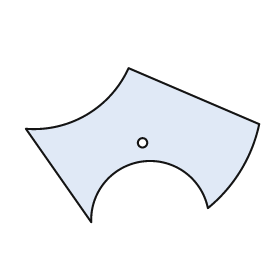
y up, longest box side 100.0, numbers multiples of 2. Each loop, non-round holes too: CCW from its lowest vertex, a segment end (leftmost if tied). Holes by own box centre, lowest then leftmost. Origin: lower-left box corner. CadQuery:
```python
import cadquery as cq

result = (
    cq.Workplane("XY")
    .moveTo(28.0, 0.0)
    .threePointArc((50.0, 26.0), (78.0, 6.0))
    .threePointArc((92.0, 22.0), (100.0, 42.0))
    .lineTo(44.0, 66.0)
    .threePointArc((26.0, 46.0), (0.0, 40.0))
    .close()
    .moveTo(50.0, 34.0)
    .circle(2.0)
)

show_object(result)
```